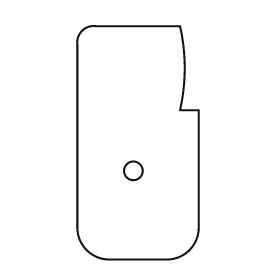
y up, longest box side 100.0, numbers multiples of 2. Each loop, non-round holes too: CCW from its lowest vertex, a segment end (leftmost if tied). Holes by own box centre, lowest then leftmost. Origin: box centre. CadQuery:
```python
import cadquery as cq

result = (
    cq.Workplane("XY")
    .moveTo(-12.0, -50.0)
    .lineTo(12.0, -50.0)
    .threePointArc((22.0, -46.0), (26.0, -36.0))
    .lineTo(26.0, 14.0)
    .lineTo(18.0, 14.0)
    .threePointArc((20.0, 32.0), (18.0, 50.0))
    .lineTo(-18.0, 50.0)
    .threePointArc((-24.0, 48.0), (-26.0, 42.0))
    .lineTo(-26.0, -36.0)
    .threePointArc((-22.0, -46.0), (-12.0, -50.0))
    .close()
    .moveTo(-2.0, -12.0)
    .circle(4.0)
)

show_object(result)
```